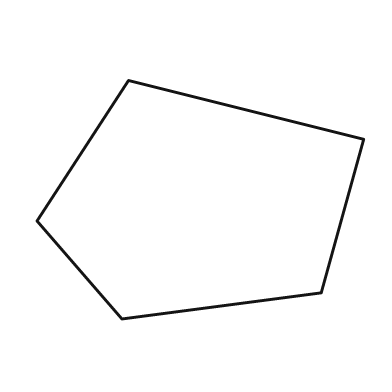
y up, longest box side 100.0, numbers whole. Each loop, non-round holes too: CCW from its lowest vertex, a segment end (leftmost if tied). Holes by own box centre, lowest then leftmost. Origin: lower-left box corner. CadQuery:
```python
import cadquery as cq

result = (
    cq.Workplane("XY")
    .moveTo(26.0, 0.0)
    .lineTo(87.0, 8.0)
    .lineTo(100.0, 55.0)
    .lineTo(28.0, 73.0)
    .lineTo(0.0, 30.0)
    .close()
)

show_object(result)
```